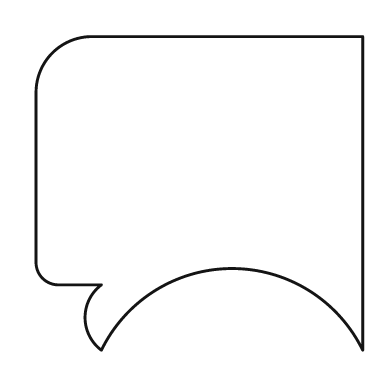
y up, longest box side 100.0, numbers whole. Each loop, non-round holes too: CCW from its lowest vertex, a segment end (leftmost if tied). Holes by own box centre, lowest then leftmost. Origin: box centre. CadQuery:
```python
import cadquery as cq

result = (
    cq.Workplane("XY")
    .moveTo(-30.0, -48.0)
    .threePointArc((10.0, -23.0), (50.0, -48.0))
    .lineTo(50.0, 48.0)
    .lineTo(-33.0, 48.0)
    .threePointArc((-45.0, 43.0), (-50.0, 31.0))
    .lineTo(-50.0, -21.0)
    .threePointArc((-48.0, -26.0), (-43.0, -28.0))
    .lineTo(-30.0, -28.0)
    .threePointArc((-35.0, -38.0), (-30.0, -48.0))
    .close()
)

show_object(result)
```